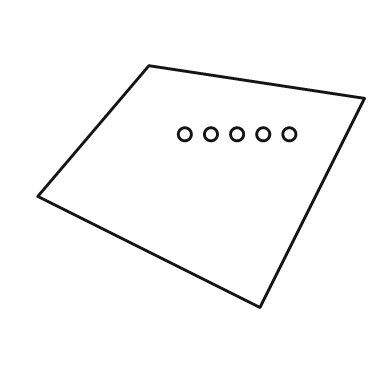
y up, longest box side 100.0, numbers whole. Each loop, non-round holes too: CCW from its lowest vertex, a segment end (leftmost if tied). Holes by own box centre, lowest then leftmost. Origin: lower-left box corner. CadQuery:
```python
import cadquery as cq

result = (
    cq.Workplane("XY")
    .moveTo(68.0, 0.0)
    .lineTo(100.0, 64.0)
    .lineTo(34.0, 74.0)
    .lineTo(0.0, 34.0)
    .close()
    .moveTo(45.0, 53.0)
    .circle(2.0)
    .moveTo(53.0, 53.0)
    .circle(2.0)
    .moveTo(61.0, 53.0)
    .circle(2.0)
    .moveTo(69.0, 53.0)
    .circle(2.0)
    .moveTo(77.0, 53.0)
    .circle(2.0)
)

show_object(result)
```